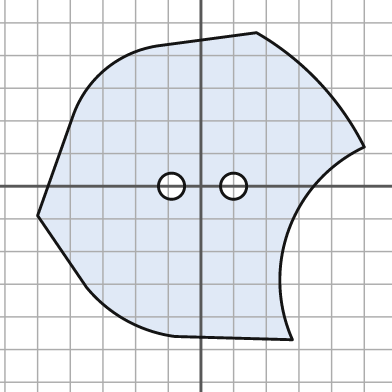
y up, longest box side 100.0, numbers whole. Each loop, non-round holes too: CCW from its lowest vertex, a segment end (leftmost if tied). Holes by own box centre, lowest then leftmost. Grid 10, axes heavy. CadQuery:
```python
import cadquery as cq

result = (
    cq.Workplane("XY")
    .moveTo(28.0, -47.0)
    .threePointArc((27.0, -13.0), (50.0, 12.0))
    .threePointArc((36.0, 32.0), (17.0, 47.0))
    .lineTo(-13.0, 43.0)
    .threePointArc((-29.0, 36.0), (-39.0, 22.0))
    .lineTo(-50.0, -9.0)
    .lineTo(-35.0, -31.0)
    .threePointArc((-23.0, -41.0), (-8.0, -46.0))
    .close()
    .moveTo(-9.0, 0.0)
    .circle(4.0)
    .moveTo(10.0, 0.0)
    .circle(4.0)
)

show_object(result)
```